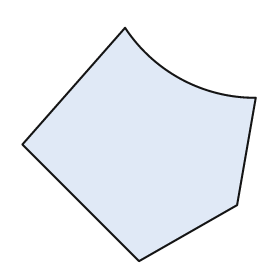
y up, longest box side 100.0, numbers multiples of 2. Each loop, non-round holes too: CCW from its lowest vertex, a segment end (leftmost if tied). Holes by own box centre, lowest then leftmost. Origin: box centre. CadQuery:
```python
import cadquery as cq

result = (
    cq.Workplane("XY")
    .moveTo(0.0, -50.0)
    .lineTo(42.0, -26.0)
    .lineTo(50.0, 20.0)
    .threePointArc((18.0, 28.0), (-6.0, 50.0))
    .lineTo(-50.0, 0.0)
    .close()
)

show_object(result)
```